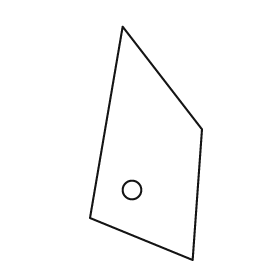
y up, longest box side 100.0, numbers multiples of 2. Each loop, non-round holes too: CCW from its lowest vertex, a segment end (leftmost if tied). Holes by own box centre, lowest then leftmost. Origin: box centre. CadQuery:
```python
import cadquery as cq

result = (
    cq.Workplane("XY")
    .moveTo(20.0, -50.0)
    .lineTo(24.0, 6.0)
    .lineTo(-10.0, 50.0)
    .lineTo(-24.0, -32.0)
    .close()
    .moveTo(-6.0, -20.0)
    .circle(4.0)
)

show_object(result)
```